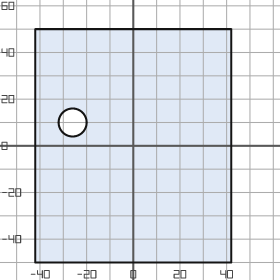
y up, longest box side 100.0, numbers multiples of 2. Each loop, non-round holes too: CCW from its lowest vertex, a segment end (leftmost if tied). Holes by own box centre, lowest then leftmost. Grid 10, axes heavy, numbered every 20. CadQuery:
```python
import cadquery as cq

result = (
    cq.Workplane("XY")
    .moveTo(-42.0, -50.0)
    .lineTo(42.0, -50.0)
    .lineTo(42.0, 50.0)
    .lineTo(-42.0, 50.0)
    .close()
    .moveTo(-26.0, 10.0)
    .circle(6.0)
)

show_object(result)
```